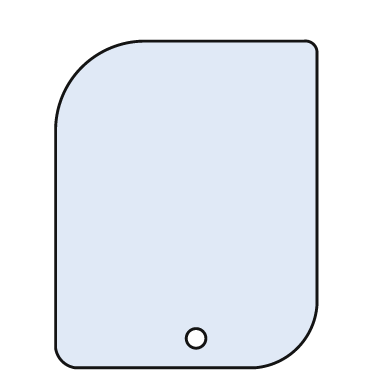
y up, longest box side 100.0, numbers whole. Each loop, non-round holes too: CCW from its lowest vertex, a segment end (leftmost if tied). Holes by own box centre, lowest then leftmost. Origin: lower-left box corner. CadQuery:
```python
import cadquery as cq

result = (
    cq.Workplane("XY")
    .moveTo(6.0, 0.0)
    .lineTo(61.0, 0.0)
    .threePointArc((74.0, 6.0), (80.0, 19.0))
    .lineTo(80.0, 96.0)
    .threePointArc((79.0, 99.0), (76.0, 100.0))
    .lineTo(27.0, 100.0)
    .threePointArc((8.0, 92.0), (0.0, 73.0))
    .lineTo(0.0, 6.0)
    .threePointArc((2.0, 2.0), (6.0, 0.0))
    .close()
    .moveTo(43.0, 9.0)
    .circle(3.0)
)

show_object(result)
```